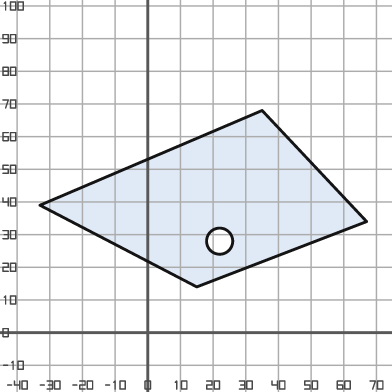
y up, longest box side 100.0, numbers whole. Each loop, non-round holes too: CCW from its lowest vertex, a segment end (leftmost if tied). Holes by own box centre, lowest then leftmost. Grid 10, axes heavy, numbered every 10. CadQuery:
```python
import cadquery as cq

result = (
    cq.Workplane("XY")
    .moveTo(15.0, 14.0)
    .lineTo(67.0, 34.0)
    .lineTo(35.0, 68.0)
    .lineTo(-33.0, 39.0)
    .close()
    .moveTo(22.0, 28.0)
    .circle(4.0)
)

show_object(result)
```